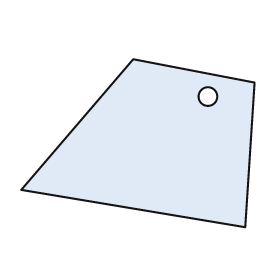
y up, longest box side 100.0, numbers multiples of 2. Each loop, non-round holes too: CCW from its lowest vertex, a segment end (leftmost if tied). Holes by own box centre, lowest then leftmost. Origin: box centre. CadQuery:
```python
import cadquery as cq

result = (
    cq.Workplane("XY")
    .moveTo(46.0, -36.0)
    .lineTo(50.0, 26.0)
    .lineTo(-2.0, 36.0)
    .lineTo(-50.0, -20.0)
    .close()
    .moveTo(30.0, 20.0)
    .circle(4.0)
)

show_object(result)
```